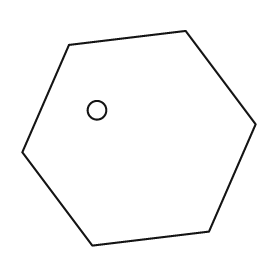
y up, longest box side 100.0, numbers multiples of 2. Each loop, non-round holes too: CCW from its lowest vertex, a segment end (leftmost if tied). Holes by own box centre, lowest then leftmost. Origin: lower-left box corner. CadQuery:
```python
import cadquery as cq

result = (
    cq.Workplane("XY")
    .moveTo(30.0, 0.0)
    .lineTo(80.0, 6.0)
    .lineTo(100.0, 52.0)
    .lineTo(70.0, 92.0)
    .lineTo(20.0, 86.0)
    .lineTo(0.0, 40.0)
    .close()
    .moveTo(32.0, 58.0)
    .circle(4.0)
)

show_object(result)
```